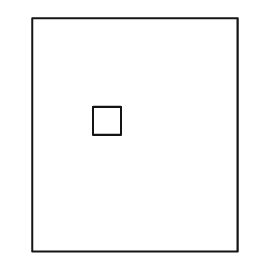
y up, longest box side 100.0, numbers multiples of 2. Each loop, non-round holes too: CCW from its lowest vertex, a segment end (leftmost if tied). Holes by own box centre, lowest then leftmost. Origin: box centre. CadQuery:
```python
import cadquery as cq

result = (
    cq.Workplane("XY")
    .moveTo(-44.0, -50.0)
    .lineTo(44.0, -50.0)
    .lineTo(44.0, 50.0)
    .lineTo(-44.0, 50.0)
    .close()
    .moveTo(-18.0, 0.0)
    .lineTo(-6.0, 0.0)
    .lineTo(-6.0, 12.0)
    .lineTo(-18.0, 12.0)
    .close()
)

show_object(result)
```